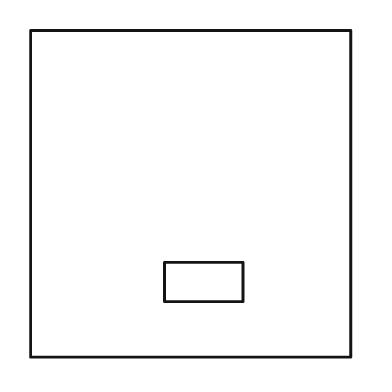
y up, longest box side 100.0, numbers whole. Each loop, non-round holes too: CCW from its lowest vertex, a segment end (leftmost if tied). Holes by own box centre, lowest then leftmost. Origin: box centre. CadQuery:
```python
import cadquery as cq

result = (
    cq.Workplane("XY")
    .moveTo(-49.0, -50.0)
    .lineTo(49.0, -50.0)
    .lineTo(49.0, 50.0)
    .lineTo(-49.0, 50.0)
    .close()
    .moveTo(-8.0, -33.0)
    .lineTo(16.0, -33.0)
    .lineTo(16.0, -21.0)
    .lineTo(-8.0, -21.0)
    .close()
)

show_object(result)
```